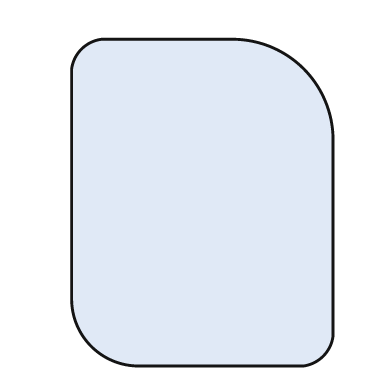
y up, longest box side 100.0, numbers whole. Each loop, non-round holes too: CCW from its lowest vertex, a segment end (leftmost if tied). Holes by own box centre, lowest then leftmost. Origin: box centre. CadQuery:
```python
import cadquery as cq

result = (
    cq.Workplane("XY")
    .moveTo(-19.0, -50.0)
    .lineTo(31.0, -50.0)
    .threePointArc((37.0, -47.0), (40.0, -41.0))
    .lineTo(40.0, 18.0)
    .threePointArc((31.0, 41.0), (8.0, 50.0))
    .lineTo(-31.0, 50.0)
    .threePointArc((-37.0, 47.0), (-40.0, 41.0))
    .lineTo(-40.0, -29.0)
    .threePointArc((-34.0, -44.0), (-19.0, -50.0))
    .close()
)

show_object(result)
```